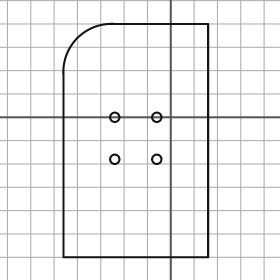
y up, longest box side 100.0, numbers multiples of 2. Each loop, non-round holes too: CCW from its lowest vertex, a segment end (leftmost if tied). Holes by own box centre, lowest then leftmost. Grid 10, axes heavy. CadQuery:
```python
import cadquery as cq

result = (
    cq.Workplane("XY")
    .moveTo(-46.0, -60.0)
    .lineTo(16.0, -60.0)
    .lineTo(16.0, 40.0)
    .lineTo(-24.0, 40.0)
    .threePointArc((-40.0, 34.0), (-46.0, 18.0))
    .close()
    .moveTo(-24.0, -18.0)
    .circle(2.0)
    .moveTo(-6.0, -18.0)
    .circle(2.0)
    .moveTo(-24.0, 0.0)
    .circle(2.0)
    .moveTo(-6.0, 0.0)
    .circle(2.0)
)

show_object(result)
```